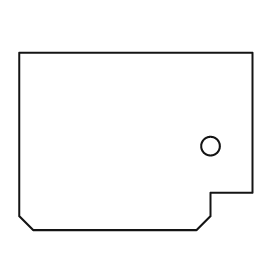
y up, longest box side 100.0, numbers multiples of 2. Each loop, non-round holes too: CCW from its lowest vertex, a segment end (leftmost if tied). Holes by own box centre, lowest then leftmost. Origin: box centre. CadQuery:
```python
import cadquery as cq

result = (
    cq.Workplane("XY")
    .moveTo(-44.0, -38.0)
    .lineTo(26.0, -38.0)
    .lineTo(32.0, -32.0)
    .lineTo(32.0, -22.0)
    .lineTo(50.0, -22.0)
    .lineTo(50.0, 38.0)
    .lineTo(-50.0, 38.0)
    .lineTo(-50.0, -32.0)
    .close()
    .moveTo(32.0, -2.0)
    .circle(4.0)
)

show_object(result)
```